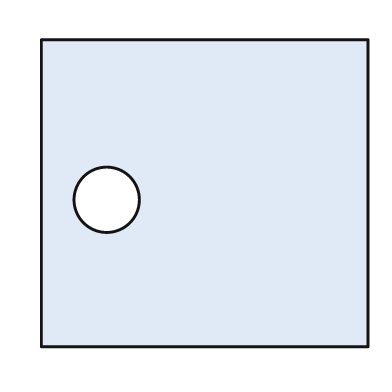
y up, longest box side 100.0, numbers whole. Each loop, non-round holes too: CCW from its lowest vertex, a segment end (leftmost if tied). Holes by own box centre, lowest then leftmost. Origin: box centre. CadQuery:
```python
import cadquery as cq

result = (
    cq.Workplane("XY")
    .moveTo(-50.0, -47.0)
    .lineTo(50.0, -47.0)
    .lineTo(50.0, 47.0)
    .lineTo(-50.0, 47.0)
    .close()
    .moveTo(-30.0, -2.0)
    .circle(10.0)
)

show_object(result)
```